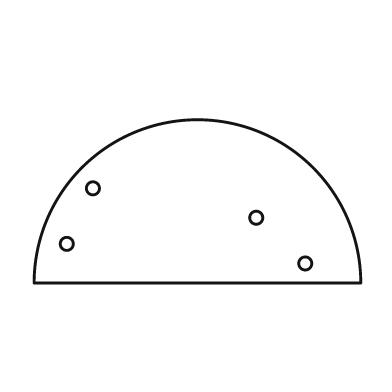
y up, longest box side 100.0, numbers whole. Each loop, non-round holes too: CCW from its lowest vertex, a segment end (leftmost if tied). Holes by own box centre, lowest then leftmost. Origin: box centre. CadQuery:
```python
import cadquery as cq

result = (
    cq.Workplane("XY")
    .moveTo(-50.0, -25.0)
    .lineTo(50.0, -25.0)
    .threePointArc((0.0, 25.0), (-50.0, -25.0))
    .close()
    .moveTo(33.0, -19.0)
    .circle(2.0)
    .moveTo(-40.0, -13.0)
    .circle(2.0)
    .moveTo(18.0, -5.0)
    .circle(2.0)
    .moveTo(-32.0, 4.0)
    .circle(2.0)
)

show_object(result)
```